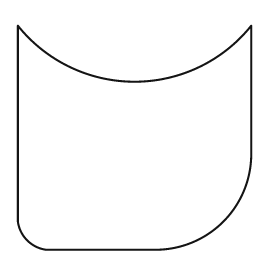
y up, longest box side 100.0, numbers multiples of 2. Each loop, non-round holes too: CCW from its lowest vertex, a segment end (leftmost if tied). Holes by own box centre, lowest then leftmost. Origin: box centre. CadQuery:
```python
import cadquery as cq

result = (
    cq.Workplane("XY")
    .moveTo(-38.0, -48.0)
    .lineTo(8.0, -48.0)
    .threePointArc((38.0, -36.0), (50.0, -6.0))
    .lineTo(50.0, 48.0)
    .threePointArc((0.0, 24.0), (-50.0, 48.0))
    .lineTo(-50.0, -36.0)
    .threePointArc((-46.0, -44.0), (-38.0, -48.0))
    .close()
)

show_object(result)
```